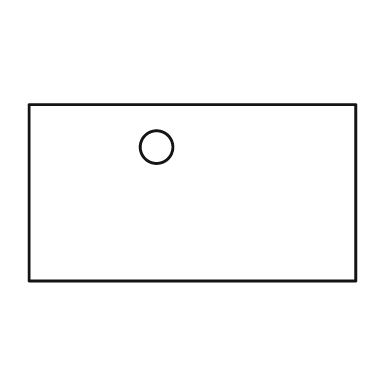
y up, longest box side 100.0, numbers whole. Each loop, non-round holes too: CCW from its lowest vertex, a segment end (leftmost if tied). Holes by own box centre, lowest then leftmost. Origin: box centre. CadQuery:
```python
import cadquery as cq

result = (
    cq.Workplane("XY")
    .moveTo(-50.0, -27.0)
    .lineTo(50.0, -27.0)
    .lineTo(50.0, 27.0)
    .lineTo(-50.0, 27.0)
    .close()
    .moveTo(-11.0, 14.0)
    .circle(5.0)
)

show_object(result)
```